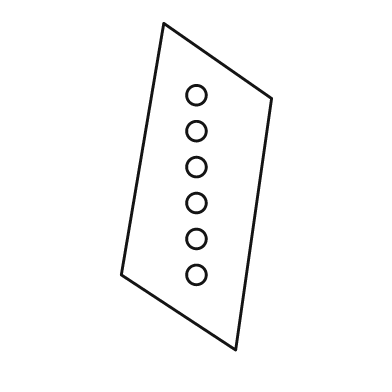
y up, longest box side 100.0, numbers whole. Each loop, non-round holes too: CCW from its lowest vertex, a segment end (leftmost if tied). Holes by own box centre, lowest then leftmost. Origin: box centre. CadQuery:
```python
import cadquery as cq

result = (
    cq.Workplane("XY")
    .moveTo(12.0, -50.0)
    .lineTo(23.0, 27.0)
    .lineTo(-10.0, 50.0)
    .lineTo(-23.0, -27.0)
    .close()
    .moveTo(0.0, -27.0)
    .circle(3.0)
    .moveTo(0.0, -16.0)
    .circle(3.0)
    .moveTo(0.0, -5.0)
    .circle(3.0)
    .moveTo(0.0, 6.0)
    .circle(3.0)
    .moveTo(0.0, 17.0)
    .circle(3.0)
    .moveTo(0.0, 28.0)
    .circle(3.0)
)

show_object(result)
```